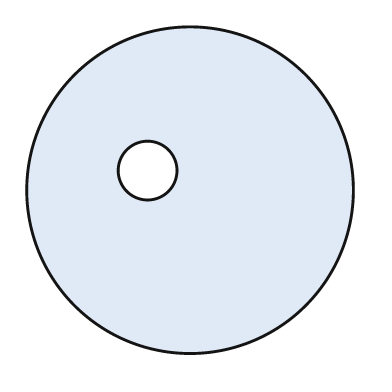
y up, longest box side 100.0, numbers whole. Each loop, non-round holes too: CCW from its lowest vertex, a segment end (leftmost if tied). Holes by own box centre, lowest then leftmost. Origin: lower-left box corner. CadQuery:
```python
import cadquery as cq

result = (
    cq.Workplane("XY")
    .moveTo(50.0, 50.0)
    .circle(50.0)
    .moveTo(37.0, 56.0)
    .circle(9.0)
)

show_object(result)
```